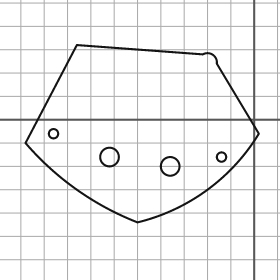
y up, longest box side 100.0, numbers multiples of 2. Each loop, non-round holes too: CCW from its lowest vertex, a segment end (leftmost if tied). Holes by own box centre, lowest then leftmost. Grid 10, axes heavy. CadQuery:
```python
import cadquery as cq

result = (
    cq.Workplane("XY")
    .moveTo(-50.0, -44.0)
    .threePointArc((-20.0, -30.0), (2.0, -6.0))
    .lineTo(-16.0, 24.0)
    .threePointArc((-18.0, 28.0), (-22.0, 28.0))
    .lineTo(-76.0, 32.0)
    .lineTo(-98.0, -10.0)
    .threePointArc((-76.0, -30.0), (-50.0, -44.0))
    .close()
    .moveTo(-36.0, -20.0)
    .circle(4.0)
    .moveTo(-62.0, -16.0)
    .circle(4.0)
    .moveTo(-14.0, -16.0)
    .circle(2.0)
    .moveTo(-86.0, -6.0)
    .circle(2.0)
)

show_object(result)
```